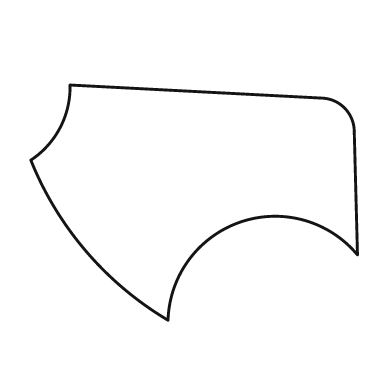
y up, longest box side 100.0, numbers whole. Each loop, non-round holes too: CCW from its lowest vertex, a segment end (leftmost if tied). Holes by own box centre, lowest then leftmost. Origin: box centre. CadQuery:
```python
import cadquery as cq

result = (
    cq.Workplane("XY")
    .moveTo(-8.0, -36.0)
    .threePointArc((14.0, -6.0), (50.0, -16.0))
    .lineTo(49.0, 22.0)
    .threePointArc((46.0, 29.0), (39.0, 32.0))
    .lineTo(-38.0, 36.0)
    .threePointArc((-41.0, 23.0), (-50.0, 13.0))
    .threePointArc((-33.0, -15.0), (-8.0, -36.0))
    .close()
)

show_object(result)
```